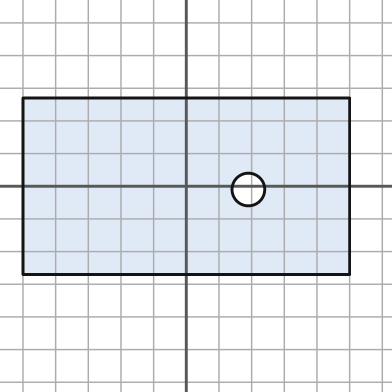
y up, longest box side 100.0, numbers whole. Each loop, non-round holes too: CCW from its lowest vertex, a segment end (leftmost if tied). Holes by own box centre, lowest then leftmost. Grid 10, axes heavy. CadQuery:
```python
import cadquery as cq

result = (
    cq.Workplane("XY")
    .moveTo(-50.0, -27.0)
    .lineTo(50.0, -27.0)
    .lineTo(50.0, 27.0)
    .lineTo(-50.0, 27.0)
    .close()
    .moveTo(19.0, -1.0)
    .circle(5.0)
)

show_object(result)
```